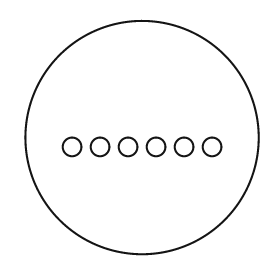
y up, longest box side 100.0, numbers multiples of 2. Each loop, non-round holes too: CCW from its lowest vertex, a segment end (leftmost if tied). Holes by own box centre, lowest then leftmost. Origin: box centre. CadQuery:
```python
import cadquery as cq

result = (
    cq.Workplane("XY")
    .moveTo(0.0, 0.0)
    .circle(50.0)
    .moveTo(-30.0, -4.0)
    .circle(4.0)
    .moveTo(-18.0, -4.0)
    .circle(4.0)
    .moveTo(-6.0, -4.0)
    .circle(4.0)
    .moveTo(6.0, -4.0)
    .circle(4.0)
    .moveTo(18.0, -4.0)
    .circle(4.0)
    .moveTo(30.0, -4.0)
    .circle(4.0)
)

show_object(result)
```